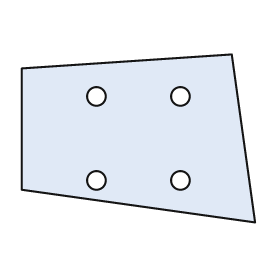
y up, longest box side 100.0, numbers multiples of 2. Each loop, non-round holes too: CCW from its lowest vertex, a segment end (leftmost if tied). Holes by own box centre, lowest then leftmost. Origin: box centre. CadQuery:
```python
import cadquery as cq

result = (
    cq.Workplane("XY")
    .moveTo(50.0, -36.0)
    .lineTo(40.0, 36.0)
    .lineTo(-50.0, 30.0)
    .lineTo(-50.0, -22.0)
    .close()
    .moveTo(-18.0, -18.0)
    .circle(4.0)
    .moveTo(18.0, -18.0)
    .circle(4.0)
    .moveTo(-18.0, 18.0)
    .circle(4.0)
    .moveTo(18.0, 18.0)
    .circle(4.0)
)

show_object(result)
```